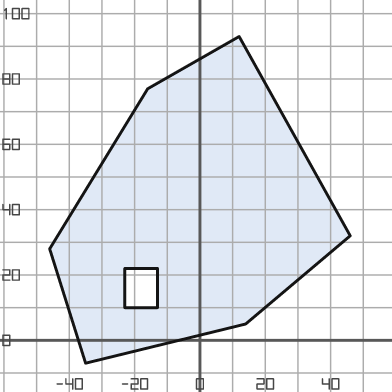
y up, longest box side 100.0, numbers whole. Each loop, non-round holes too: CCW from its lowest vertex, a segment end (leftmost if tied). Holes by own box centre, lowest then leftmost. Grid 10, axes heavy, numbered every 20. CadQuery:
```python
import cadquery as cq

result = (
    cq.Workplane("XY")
    .moveTo(-35.0, -7.0)
    .lineTo(14.0, 5.0)
    .lineTo(46.0, 32.0)
    .lineTo(12.0, 93.0)
    .lineTo(-16.0, 77.0)
    .lineTo(-46.0, 28.0)
    .close()
    .moveTo(-23.0, 10.0)
    .lineTo(-13.0, 10.0)
    .lineTo(-13.0, 22.0)
    .lineTo(-23.0, 22.0)
    .close()
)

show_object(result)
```